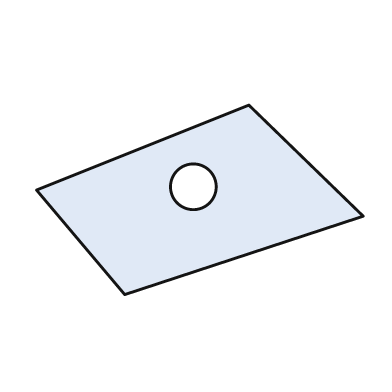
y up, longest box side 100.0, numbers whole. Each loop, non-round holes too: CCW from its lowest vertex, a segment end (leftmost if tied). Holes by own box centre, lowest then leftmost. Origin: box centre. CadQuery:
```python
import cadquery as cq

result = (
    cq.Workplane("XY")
    .moveTo(-23.0, -29.0)
    .lineTo(50.0, -5.0)
    .lineTo(15.0, 29.0)
    .lineTo(-50.0, 3.0)
    .close()
    .moveTo(-2.0, 4.0)
    .circle(7.0)
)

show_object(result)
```